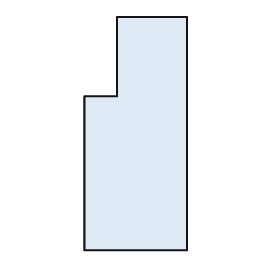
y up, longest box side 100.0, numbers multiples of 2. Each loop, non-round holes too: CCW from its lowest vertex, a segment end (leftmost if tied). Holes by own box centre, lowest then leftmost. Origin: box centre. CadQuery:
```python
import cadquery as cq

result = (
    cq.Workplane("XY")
    .moveTo(-22.0, -50.0)
    .lineTo(22.0, -50.0)
    .lineTo(22.0, 50.0)
    .lineTo(-8.0, 50.0)
    .lineTo(-8.0, 16.0)
    .lineTo(-22.0, 16.0)
    .close()
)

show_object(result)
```